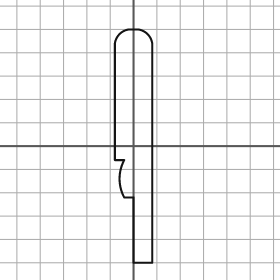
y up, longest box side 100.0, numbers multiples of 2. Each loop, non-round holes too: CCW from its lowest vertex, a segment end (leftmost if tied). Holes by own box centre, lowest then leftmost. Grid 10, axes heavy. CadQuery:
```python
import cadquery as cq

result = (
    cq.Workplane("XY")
    .moveTo(0.0, -50.0)
    .lineTo(8.0, -50.0)
    .lineTo(8.0, 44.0)
    .threePointArc((6.0, 48.0), (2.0, 50.0))
    .lineTo(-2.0, 50.0)
    .threePointArc((-6.0, 48.0), (-8.0, 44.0))
    .lineTo(-8.0, -6.0)
    .lineTo(-4.0, -6.0)
    .threePointArc((-6.0, -14.0), (-4.0, -22.0))
    .lineTo(0.0, -22.0)
    .close()
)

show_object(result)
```